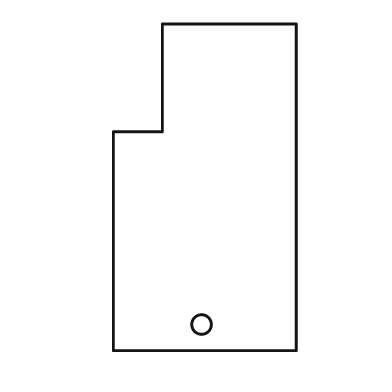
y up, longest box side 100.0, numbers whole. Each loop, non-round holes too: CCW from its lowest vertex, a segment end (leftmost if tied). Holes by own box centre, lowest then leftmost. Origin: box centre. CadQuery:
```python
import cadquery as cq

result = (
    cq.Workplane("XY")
    .moveTo(-28.0, -50.0)
    .lineTo(28.0, -50.0)
    .lineTo(28.0, 50.0)
    .lineTo(-13.0, 50.0)
    .lineTo(-13.0, 17.0)
    .lineTo(-28.0, 17.0)
    .close()
    .moveTo(-1.0, -42.0)
    .circle(3.0)
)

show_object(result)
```